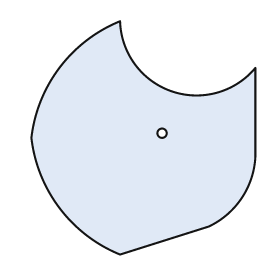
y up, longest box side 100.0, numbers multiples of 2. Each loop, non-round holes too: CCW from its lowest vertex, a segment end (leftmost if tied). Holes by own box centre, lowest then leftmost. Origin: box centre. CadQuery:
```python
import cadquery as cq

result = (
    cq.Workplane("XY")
    .moveTo(-10.0, -50.0)
    .lineTo(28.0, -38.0)
    .threePointArc((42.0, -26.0), (48.0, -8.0))
    .lineTo(48.0, 30.0)
    .threePointArc((12.0, 20.0), (-10.0, 50.0))
    .threePointArc((-36.0, 30.0), (-48.0, 0.0))
    .threePointArc((-36.0, -30.0), (-10.0, -50.0))
    .close()
    .moveTo(8.0, 2.0)
    .circle(2.0)
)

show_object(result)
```